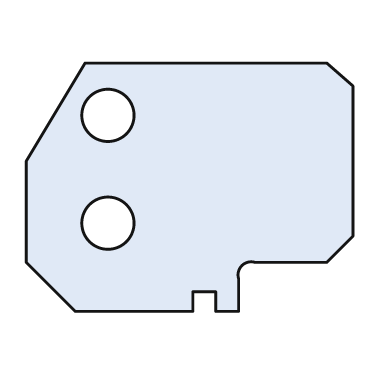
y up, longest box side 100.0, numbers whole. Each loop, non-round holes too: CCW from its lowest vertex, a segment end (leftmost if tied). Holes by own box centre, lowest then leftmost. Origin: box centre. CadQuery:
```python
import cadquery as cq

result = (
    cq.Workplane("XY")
    .moveTo(-35.0, -38.0)
    .lineTo(1.0, -38.0)
    .lineTo(1.0, -32.0)
    .lineTo(8.0, -32.0)
    .lineTo(8.0, -38.0)
    .lineTo(15.0, -38.0)
    .lineTo(15.0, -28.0)
    .threePointArc((16.0, -24.0), (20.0, -23.0))
    .lineTo(42.0, -23.0)
    .lineTo(50.0, -15.0)
    .lineTo(50.0, 31.0)
    .lineTo(42.0, 38.0)
    .lineTo(-32.0, 38.0)
    .lineTo(-50.0, 8.0)
    .lineTo(-50.0, -23.0)
    .close()
    .moveTo(-25.0, -11.0)
    .circle(8.0)
    .moveTo(-25.0, 22.0)
    .circle(8.0)
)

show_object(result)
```